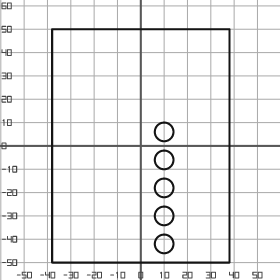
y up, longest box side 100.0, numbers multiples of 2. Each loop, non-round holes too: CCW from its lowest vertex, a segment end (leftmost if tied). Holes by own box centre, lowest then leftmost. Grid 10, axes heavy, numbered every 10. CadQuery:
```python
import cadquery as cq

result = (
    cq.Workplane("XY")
    .moveTo(-38.0, -50.0)
    .lineTo(38.0, -50.0)
    .lineTo(38.0, 50.0)
    .lineTo(-38.0, 50.0)
    .close()
    .moveTo(10.0, -42.0)
    .circle(4.0)
    .moveTo(10.0, -30.0)
    .circle(4.0)
    .moveTo(10.0, -18.0)
    .circle(4.0)
    .moveTo(10.0, -6.0)
    .circle(4.0)
    .moveTo(10.0, 6.0)
    .circle(4.0)
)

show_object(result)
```